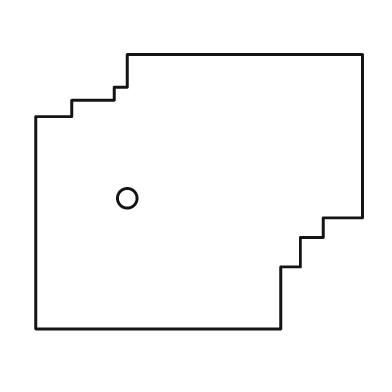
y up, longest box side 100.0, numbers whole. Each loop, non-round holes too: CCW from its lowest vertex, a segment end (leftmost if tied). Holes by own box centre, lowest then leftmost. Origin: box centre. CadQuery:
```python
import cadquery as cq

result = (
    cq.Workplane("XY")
    .moveTo(-50.0, -42.0)
    .lineTo(25.0, -42.0)
    .lineTo(25.0, -23.0)
    .lineTo(31.0, -23.0)
    .lineTo(31.0, -14.0)
    .lineTo(38.0, -14.0)
    .lineTo(38.0, -8.0)
    .lineTo(50.0, -8.0)
    .lineTo(50.0, 42.0)
    .lineTo(-22.0, 42.0)
    .lineTo(-22.0, 32.0)
    .lineTo(-26.0, 32.0)
    .lineTo(-26.0, 28.0)
    .lineTo(-39.0, 28.0)
    .lineTo(-39.0, 23.0)
    .lineTo(-50.0, 23.0)
    .close()
    .moveTo(-22.0, -2.0)
    .circle(3.0)
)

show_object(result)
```